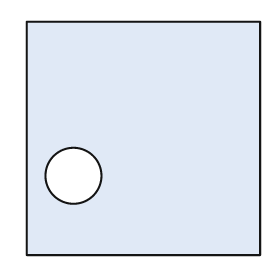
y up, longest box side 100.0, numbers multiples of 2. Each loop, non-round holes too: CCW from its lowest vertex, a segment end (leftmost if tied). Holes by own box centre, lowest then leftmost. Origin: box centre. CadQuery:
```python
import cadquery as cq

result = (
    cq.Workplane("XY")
    .moveTo(-50.0, -50.0)
    .lineTo(50.0, -50.0)
    .lineTo(50.0, 50.0)
    .lineTo(-50.0, 50.0)
    .close()
    .moveTo(-30.0, -16.0)
    .circle(12.0)
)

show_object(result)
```